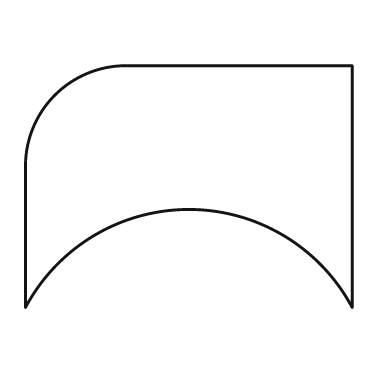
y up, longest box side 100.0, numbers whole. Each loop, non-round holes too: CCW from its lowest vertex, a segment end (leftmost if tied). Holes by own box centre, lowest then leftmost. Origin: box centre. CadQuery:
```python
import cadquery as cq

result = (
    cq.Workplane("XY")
    .moveTo(-50.0, -37.0)
    .threePointArc((0.0, -7.0), (50.0, -37.0))
    .lineTo(50.0, 37.0)
    .lineTo(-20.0, 37.0)
    .threePointArc((-41.0, 28.0), (-50.0, 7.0))
    .close()
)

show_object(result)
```